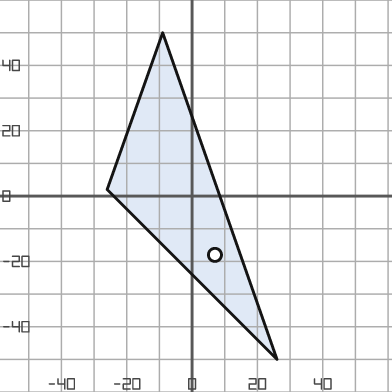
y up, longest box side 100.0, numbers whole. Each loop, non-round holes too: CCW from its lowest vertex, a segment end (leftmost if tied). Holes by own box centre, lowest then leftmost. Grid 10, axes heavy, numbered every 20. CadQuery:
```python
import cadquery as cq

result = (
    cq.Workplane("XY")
    .moveTo(26.0, -50.0)
    .lineTo(-9.0, 50.0)
    .lineTo(-26.0, 2.0)
    .close()
    .moveTo(7.0, -18.0)
    .circle(2.0)
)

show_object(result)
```